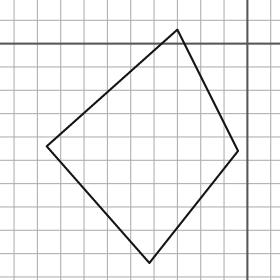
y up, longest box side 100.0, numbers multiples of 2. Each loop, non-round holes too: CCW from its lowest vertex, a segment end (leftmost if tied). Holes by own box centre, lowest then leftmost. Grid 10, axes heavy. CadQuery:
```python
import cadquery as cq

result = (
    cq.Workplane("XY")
    .moveTo(-42.0, -94.0)
    .lineTo(-4.0, -46.0)
    .lineTo(-30.0, 6.0)
    .lineTo(-86.0, -44.0)
    .close()
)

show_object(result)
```